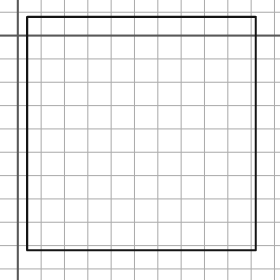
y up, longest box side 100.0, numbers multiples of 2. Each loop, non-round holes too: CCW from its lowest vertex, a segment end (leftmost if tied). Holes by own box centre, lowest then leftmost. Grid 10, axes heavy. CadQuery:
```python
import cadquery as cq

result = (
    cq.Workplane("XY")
    .moveTo(4.0, -92.0)
    .lineTo(102.0, -92.0)
    .lineTo(102.0, 8.0)
    .lineTo(4.0, 8.0)
    .close()
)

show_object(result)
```